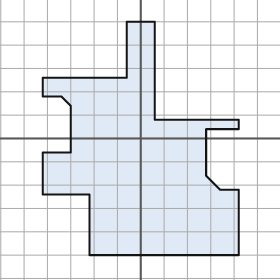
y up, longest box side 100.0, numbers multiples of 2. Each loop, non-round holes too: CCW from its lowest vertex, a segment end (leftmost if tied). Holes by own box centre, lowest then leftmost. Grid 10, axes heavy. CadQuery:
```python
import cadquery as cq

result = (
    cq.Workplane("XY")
    .moveTo(-22.0, -50.0)
    .lineTo(42.0, -50.0)
    .lineTo(42.0, -22.0)
    .lineTo(34.0, -22.0)
    .lineTo(28.0, -16.0)
    .lineTo(28.0, 4.0)
    .lineTo(42.0, 4.0)
    .lineTo(42.0, 8.0)
    .lineTo(6.0, 8.0)
    .lineTo(6.0, 50.0)
    .lineTo(-6.0, 50.0)
    .lineTo(-6.0, 26.0)
    .lineTo(-42.0, 26.0)
    .lineTo(-42.0, 18.0)
    .lineTo(-34.0, 18.0)
    .lineTo(-30.0, 14.0)
    .lineTo(-30.0, -6.0)
    .lineTo(-42.0, -6.0)
    .lineTo(-42.0, -24.0)
    .lineTo(-22.0, -24.0)
    .close()
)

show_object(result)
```